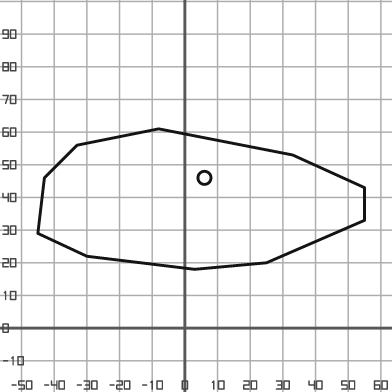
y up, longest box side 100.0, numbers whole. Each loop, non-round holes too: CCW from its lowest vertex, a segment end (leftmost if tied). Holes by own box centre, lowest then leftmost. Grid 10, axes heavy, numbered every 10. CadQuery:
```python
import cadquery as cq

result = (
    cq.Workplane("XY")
    .moveTo(3.0, 18.0)
    .lineTo(25.0, 20.0)
    .lineTo(55.0, 33.0)
    .lineTo(55.0, 43.0)
    .lineTo(33.0, 53.0)
    .lineTo(-8.0, 61.0)
    .lineTo(-33.0, 56.0)
    .lineTo(-43.0, 46.0)
    .lineTo(-45.0, 29.0)
    .lineTo(-30.0, 22.0)
    .close()
    .moveTo(6.0, 46.0)
    .circle(2.0)
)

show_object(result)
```